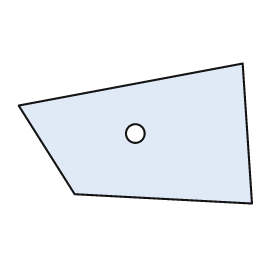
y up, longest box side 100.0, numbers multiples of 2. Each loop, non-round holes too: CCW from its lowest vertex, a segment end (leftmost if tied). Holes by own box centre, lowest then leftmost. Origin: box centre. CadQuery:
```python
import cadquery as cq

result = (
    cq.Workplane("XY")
    .moveTo(50.0, -30.0)
    .lineTo(46.0, 30.0)
    .lineTo(-50.0, 12.0)
    .lineTo(-26.0, -26.0)
    .close()
    .moveTo(0.0, 0.0)
    .circle(4.0)
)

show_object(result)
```